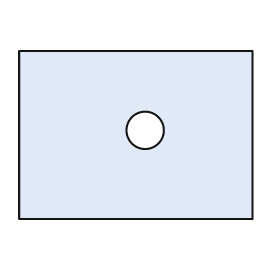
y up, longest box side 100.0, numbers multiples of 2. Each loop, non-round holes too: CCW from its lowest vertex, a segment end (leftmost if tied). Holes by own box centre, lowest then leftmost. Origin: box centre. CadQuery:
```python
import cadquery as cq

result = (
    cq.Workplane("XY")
    .moveTo(-50.0, -36.0)
    .lineTo(50.0, -36.0)
    .lineTo(50.0, 36.0)
    .lineTo(-50.0, 36.0)
    .close()
    .moveTo(4.0, 2.0)
    .circle(8.0)
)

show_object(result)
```